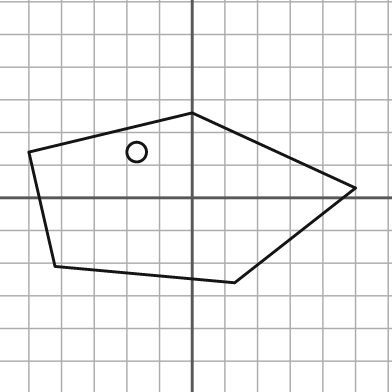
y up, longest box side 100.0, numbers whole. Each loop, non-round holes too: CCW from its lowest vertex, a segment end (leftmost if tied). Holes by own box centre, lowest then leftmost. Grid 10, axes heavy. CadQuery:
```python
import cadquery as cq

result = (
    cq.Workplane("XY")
    .moveTo(13.0, -26.0)
    .lineTo(50.0, 3.0)
    .lineTo(0.0, 26.0)
    .lineTo(-50.0, 14.0)
    .lineTo(-42.0, -21.0)
    .close()
    .moveTo(-17.0, 14.0)
    .circle(3.0)
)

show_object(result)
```